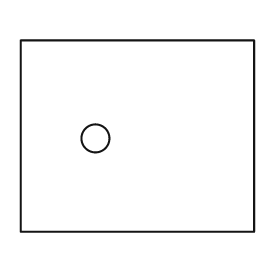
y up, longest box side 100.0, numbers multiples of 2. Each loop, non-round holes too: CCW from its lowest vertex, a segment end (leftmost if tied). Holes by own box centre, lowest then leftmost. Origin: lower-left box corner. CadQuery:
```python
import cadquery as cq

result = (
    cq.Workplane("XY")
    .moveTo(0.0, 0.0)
    .lineTo(100.0, 0.0)
    .lineTo(100.0, 82.0)
    .lineTo(0.0, 82.0)
    .close()
    .moveTo(32.0, 40.0)
    .circle(6.0)
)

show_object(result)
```